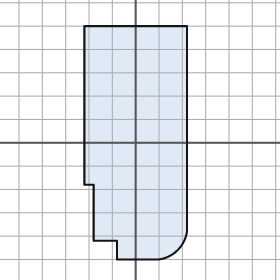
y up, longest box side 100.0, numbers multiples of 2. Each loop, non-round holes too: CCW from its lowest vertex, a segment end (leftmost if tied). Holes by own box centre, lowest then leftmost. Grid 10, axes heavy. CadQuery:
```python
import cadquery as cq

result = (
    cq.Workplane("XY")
    .moveTo(-8.0, -50.0)
    .lineTo(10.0, -50.0)
    .threePointArc((18.0, -46.0), (22.0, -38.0))
    .lineTo(22.0, 50.0)
    .lineTo(-22.0, 50.0)
    .lineTo(-22.0, -18.0)
    .lineTo(-18.0, -18.0)
    .lineTo(-18.0, -42.0)
    .lineTo(-8.0, -42.0)
    .close()
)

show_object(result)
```